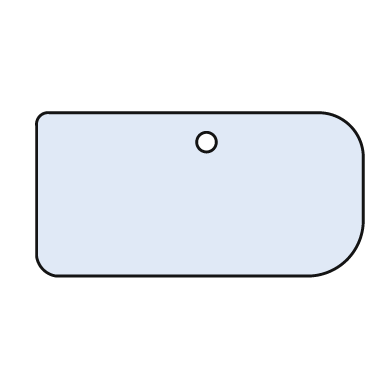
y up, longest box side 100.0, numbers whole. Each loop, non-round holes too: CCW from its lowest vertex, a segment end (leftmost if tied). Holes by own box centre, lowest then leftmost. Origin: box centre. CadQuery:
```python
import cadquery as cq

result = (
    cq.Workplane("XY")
    .moveTo(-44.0, -25.0)
    .lineTo(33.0, -25.0)
    .threePointArc((45.0, -20.0), (50.0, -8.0))
    .lineTo(50.0, 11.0)
    .threePointArc((46.0, 21.0), (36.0, 25.0))
    .lineTo(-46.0, 25.0)
    .threePointArc((-49.0, 24.0), (-50.0, 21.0))
    .lineTo(-50.0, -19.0)
    .threePointArc((-48.0, -23.0), (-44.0, -25.0))
    .close()
    .moveTo(2.0, 16.0)
    .circle(3.0)
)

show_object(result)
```